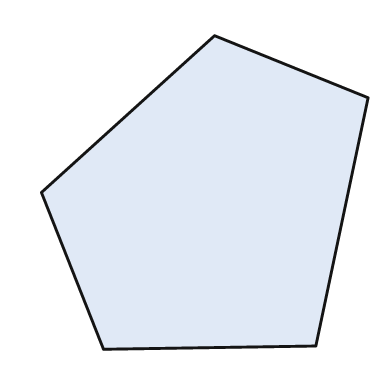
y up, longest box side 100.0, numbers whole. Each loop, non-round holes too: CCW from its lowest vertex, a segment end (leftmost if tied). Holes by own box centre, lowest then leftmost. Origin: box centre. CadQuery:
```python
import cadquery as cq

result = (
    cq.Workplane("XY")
    .moveTo(-31.0, -48.0)
    .lineTo(34.0, -47.0)
    .lineTo(50.0, 29.0)
    .lineTo(3.0, 48.0)
    .lineTo(-50.0, 0.0)
    .close()
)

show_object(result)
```